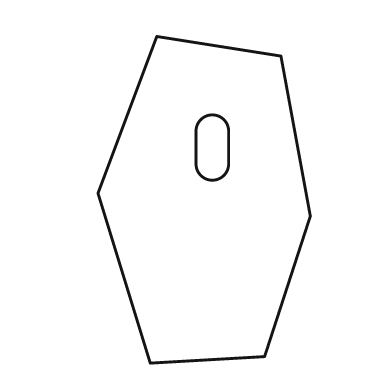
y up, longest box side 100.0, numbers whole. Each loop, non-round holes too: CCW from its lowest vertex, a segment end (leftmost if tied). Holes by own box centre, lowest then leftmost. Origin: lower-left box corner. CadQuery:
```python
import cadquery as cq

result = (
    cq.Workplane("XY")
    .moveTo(16.0, 0.0)
    .lineTo(51.0, 2.0)
    .lineTo(65.0, 45.0)
    .lineTo(56.0, 94.0)
    .lineTo(18.0, 100.0)
    .lineTo(0.0, 52.0)
    .close()
    .moveTo(30.0, 61.0)
    .threePointArc((35.0, 56.0), (40.0, 61.0))
    .lineTo(40.0, 71.0)
    .threePointArc((35.0, 76.0), (30.0, 71.0))
    .close()
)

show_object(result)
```